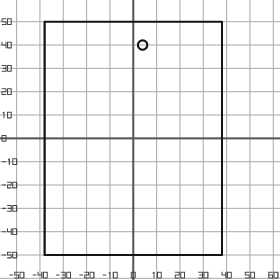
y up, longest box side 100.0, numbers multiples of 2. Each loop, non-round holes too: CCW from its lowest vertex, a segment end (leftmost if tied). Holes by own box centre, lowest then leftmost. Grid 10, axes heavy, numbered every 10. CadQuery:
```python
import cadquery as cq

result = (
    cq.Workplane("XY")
    .moveTo(-38.0, -50.0)
    .lineTo(38.0, -50.0)
    .lineTo(38.0, 50.0)
    .lineTo(-38.0, 50.0)
    .close()
    .moveTo(4.0, 40.0)
    .circle(2.0)
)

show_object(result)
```